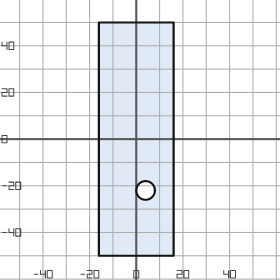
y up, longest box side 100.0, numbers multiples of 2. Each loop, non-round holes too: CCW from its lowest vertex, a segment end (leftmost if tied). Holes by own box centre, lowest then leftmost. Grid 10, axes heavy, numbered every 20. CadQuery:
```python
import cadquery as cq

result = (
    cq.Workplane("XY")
    .moveTo(-16.0, -50.0)
    .lineTo(16.0, -50.0)
    .lineTo(16.0, 50.0)
    .lineTo(-16.0, 50.0)
    .close()
    .moveTo(4.0, -22.0)
    .circle(4.0)
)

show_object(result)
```